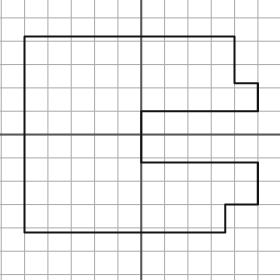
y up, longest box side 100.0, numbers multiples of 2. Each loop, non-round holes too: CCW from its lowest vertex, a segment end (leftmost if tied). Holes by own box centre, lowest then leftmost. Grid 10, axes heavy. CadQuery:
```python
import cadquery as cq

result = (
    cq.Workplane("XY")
    .moveTo(-50.0, -42.0)
    .lineTo(36.0, -42.0)
    .lineTo(36.0, -30.0)
    .lineTo(50.0, -30.0)
    .lineTo(50.0, -12.0)
    .lineTo(0.0, -12.0)
    .lineTo(0.0, 10.0)
    .lineTo(50.0, 10.0)
    .lineTo(50.0, 22.0)
    .lineTo(40.0, 22.0)
    .lineTo(40.0, 42.0)
    .lineTo(-50.0, 42.0)
    .close()
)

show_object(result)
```